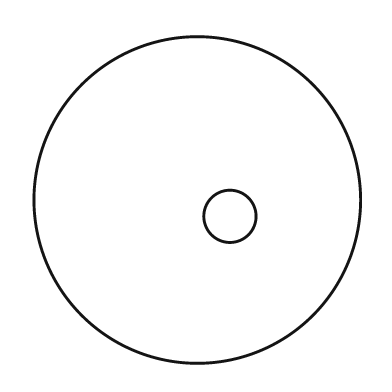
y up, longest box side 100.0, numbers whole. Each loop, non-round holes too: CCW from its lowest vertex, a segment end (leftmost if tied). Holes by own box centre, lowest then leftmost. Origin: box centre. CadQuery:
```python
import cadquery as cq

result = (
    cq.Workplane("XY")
    .moveTo(0.0, 0.0)
    .circle(50.0)
    .moveTo(10.0, -5.0)
    .circle(8.0)
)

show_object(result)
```